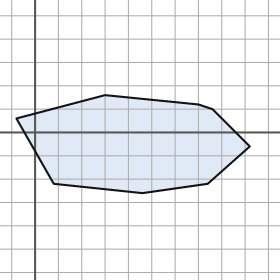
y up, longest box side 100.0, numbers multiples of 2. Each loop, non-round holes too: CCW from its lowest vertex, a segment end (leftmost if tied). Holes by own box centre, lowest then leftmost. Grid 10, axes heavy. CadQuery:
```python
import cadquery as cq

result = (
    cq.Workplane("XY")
    .moveTo(46.0, -26.0)
    .lineTo(74.0, -22.0)
    .lineTo(92.0, -6.0)
    .lineTo(76.0, 10.0)
    .lineTo(70.0, 12.0)
    .lineTo(30.0, 16.0)
    .lineTo(-8.0, 6.0)
    .lineTo(8.0, -22.0)
    .close()
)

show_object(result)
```